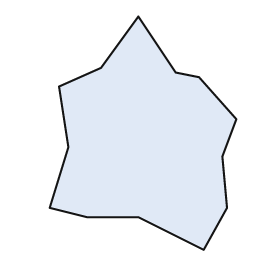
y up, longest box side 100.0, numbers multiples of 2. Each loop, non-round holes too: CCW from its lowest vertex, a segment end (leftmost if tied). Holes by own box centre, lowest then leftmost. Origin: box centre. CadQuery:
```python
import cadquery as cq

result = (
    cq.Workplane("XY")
    .moveTo(26.0, -50.0)
    .lineTo(36.0, -32.0)
    .lineTo(34.0, -10.0)
    .lineTo(40.0, 6.0)
    .lineTo(24.0, 24.0)
    .lineTo(14.0, 26.0)
    .lineTo(-2.0, 50.0)
    .lineTo(-18.0, 28.0)
    .lineTo(-36.0, 20.0)
    .lineTo(-32.0, -6.0)
    .lineTo(-40.0, -32.0)
    .lineTo(-24.0, -36.0)
    .lineTo(-2.0, -36.0)
    .close()
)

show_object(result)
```